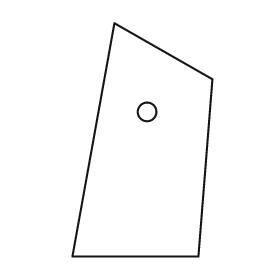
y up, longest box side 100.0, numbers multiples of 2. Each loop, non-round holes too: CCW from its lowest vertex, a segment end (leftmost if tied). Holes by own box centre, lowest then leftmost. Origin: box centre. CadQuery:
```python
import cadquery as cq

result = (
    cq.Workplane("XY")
    .moveTo(-30.0, -50.0)
    .lineTo(24.0, -50.0)
    .lineTo(30.0, 26.0)
    .lineTo(-12.0, 50.0)
    .close()
    .moveTo(2.0, 12.0)
    .circle(4.0)
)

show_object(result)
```